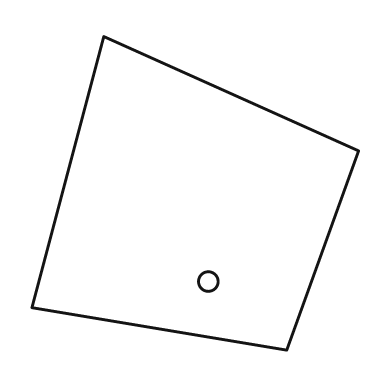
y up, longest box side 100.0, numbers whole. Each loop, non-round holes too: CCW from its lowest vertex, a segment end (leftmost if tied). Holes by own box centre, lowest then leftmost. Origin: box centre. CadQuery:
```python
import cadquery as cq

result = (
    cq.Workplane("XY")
    .moveTo(28.0, -48.0)
    .lineTo(50.0, 13.0)
    .lineTo(-28.0, 48.0)
    .lineTo(-50.0, -35.0)
    .close()
    .moveTo(4.0, -27.0)
    .circle(3.0)
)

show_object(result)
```